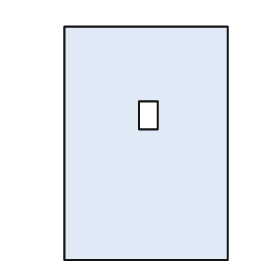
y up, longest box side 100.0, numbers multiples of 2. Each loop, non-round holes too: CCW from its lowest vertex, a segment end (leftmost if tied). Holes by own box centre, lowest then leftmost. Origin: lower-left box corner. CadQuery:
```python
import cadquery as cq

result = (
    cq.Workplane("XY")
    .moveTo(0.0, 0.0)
    .lineTo(70.0, 0.0)
    .lineTo(70.0, 100.0)
    .lineTo(0.0, 100.0)
    .close()
    .moveTo(32.0, 56.0)
    .lineTo(40.0, 56.0)
    .lineTo(40.0, 68.0)
    .lineTo(32.0, 68.0)
    .close()
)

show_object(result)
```